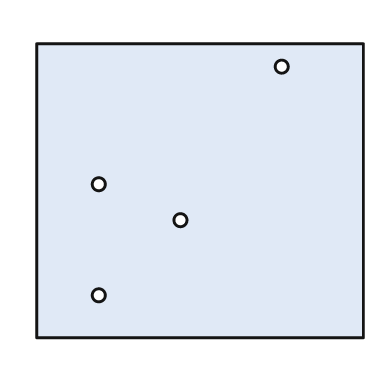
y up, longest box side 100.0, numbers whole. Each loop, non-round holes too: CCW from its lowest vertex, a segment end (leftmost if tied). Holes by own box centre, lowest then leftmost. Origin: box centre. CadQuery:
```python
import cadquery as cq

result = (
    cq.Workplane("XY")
    .moveTo(-50.0, -45.0)
    .lineTo(50.0, -45.0)
    .lineTo(50.0, 45.0)
    .lineTo(-50.0, 45.0)
    .close()
    .moveTo(-31.0, -32.0)
    .circle(2.0)
    .moveTo(-6.0, -9.0)
    .circle(2.0)
    .moveTo(-31.0, 2.0)
    .circle(2.0)
    .moveTo(25.0, 38.0)
    .circle(2.0)
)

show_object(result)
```